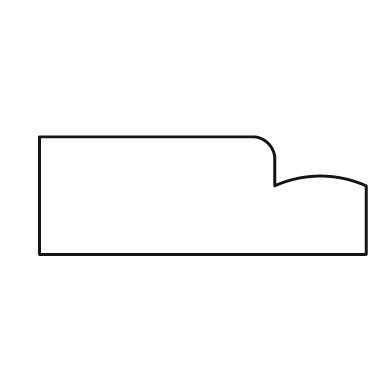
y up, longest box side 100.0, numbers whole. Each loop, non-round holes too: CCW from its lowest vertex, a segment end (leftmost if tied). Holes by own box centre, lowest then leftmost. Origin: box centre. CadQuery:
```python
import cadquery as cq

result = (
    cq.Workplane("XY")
    .moveTo(-50.0, -18.0)
    .lineTo(50.0, -18.0)
    .lineTo(50.0, 3.0)
    .threePointArc((36.0, 6.0), (22.0, 3.0))
    .lineTo(22.0, 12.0)
    .threePointArc((20.0, 16.0), (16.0, 18.0))
    .lineTo(-50.0, 18.0)
    .close()
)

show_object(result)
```